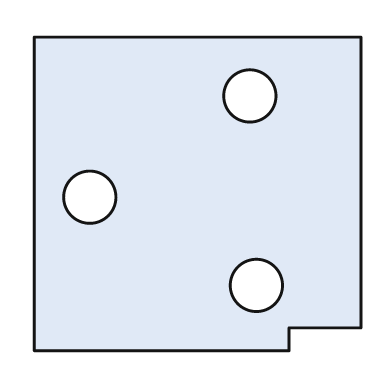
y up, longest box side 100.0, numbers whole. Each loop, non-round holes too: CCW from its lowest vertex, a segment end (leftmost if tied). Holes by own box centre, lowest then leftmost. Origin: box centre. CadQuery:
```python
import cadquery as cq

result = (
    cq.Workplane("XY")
    .moveTo(-50.0, -48.0)
    .lineTo(28.0, -48.0)
    .lineTo(28.0, -41.0)
    .lineTo(50.0, -41.0)
    .lineTo(50.0, 48.0)
    .lineTo(-50.0, 48.0)
    .close()
    .moveTo(18.0, -28.0)
    .circle(8.0)
    .moveTo(-33.0, -1.0)
    .circle(8.0)
    .moveTo(16.0, 30.0)
    .circle(8.0)
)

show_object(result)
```